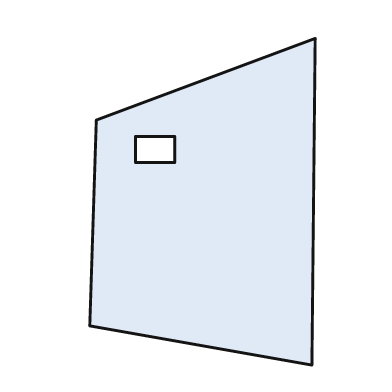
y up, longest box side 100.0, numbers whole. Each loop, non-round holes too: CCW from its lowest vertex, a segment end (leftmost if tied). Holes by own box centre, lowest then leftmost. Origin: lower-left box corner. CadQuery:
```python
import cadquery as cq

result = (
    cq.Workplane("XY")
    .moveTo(68.0, 0.0)
    .lineTo(69.0, 100.0)
    .lineTo(2.0, 75.0)
    .lineTo(0.0, 12.0)
    .close()
    .moveTo(14.0, 62.0)
    .lineTo(26.0, 62.0)
    .lineTo(26.0, 70.0)
    .lineTo(14.0, 70.0)
    .close()
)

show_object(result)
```